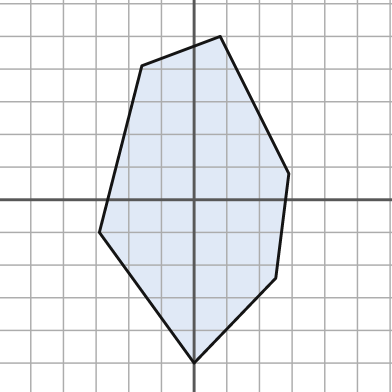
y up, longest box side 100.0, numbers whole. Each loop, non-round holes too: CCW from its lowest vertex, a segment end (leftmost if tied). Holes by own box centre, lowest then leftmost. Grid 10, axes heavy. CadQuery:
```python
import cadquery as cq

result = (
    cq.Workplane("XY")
    .moveTo(0.0, -50.0)
    .lineTo(25.0, -24.0)
    .lineTo(29.0, 8.0)
    .lineTo(8.0, 50.0)
    .lineTo(-16.0, 41.0)
    .lineTo(-29.0, -10.0)
    .close()
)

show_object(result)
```